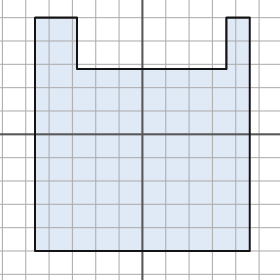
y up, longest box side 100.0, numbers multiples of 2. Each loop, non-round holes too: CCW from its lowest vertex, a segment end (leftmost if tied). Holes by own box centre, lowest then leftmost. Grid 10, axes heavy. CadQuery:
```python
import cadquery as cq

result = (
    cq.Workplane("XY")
    .moveTo(-46.0, -50.0)
    .lineTo(46.0, -50.0)
    .lineTo(46.0, 50.0)
    .lineTo(36.0, 50.0)
    .lineTo(36.0, 28.0)
    .lineTo(-28.0, 28.0)
    .lineTo(-28.0, 50.0)
    .lineTo(-46.0, 50.0)
    .close()
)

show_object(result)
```